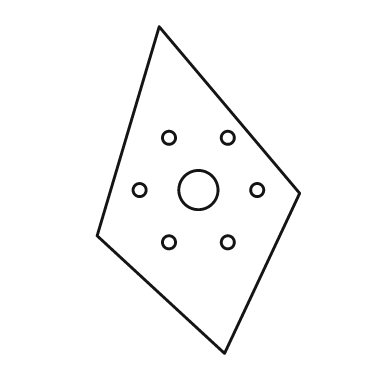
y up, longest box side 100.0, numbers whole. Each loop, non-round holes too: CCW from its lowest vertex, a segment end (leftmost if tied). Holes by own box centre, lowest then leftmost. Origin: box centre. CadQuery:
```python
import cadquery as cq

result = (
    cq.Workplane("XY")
    .moveTo(8.0, -50.0)
    .lineTo(31.0, -1.0)
    .lineTo(-12.0, 50.0)
    .lineTo(-31.0, -14.0)
    .close()
    .moveTo(-9.0, -16.0)
    .circle(2.0)
    .moveTo(9.0, -16.0)
    .circle(2.0)
    .moveTo(-18.0, 0.0)
    .circle(2.0)
    .moveTo(0.0, 0.0)
    .circle(6.0)
    .moveTo(18.0, 0.0)
    .circle(2.0)
    .moveTo(-9.0, 16.0)
    .circle(2.0)
    .moveTo(9.0, 16.0)
    .circle(2.0)
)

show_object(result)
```